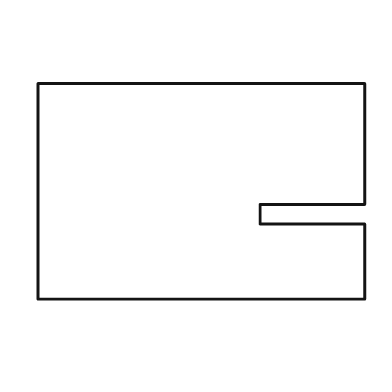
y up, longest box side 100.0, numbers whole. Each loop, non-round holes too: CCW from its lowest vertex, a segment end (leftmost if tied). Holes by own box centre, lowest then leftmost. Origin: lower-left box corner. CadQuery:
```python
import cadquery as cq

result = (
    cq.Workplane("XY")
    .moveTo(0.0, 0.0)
    .lineTo(100.0, 0.0)
    .lineTo(100.0, 23.0)
    .lineTo(68.0, 23.0)
    .lineTo(68.0, 29.0)
    .lineTo(100.0, 29.0)
    .lineTo(100.0, 66.0)
    .lineTo(0.0, 66.0)
    .close()
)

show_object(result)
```